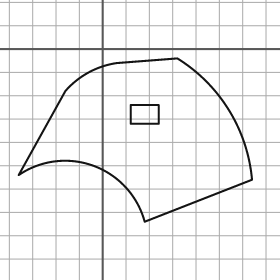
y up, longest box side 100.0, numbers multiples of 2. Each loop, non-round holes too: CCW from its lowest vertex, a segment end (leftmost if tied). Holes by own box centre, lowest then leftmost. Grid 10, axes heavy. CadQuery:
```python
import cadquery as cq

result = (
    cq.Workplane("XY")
    .moveTo(18.0, -74.0)
    .lineTo(64.0, -56.0)
    .threePointArc((54.0, -26.0), (32.0, -4.0))
    .lineTo(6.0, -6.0)
    .threePointArc((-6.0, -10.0), (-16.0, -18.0))
    .lineTo(-36.0, -54.0)
    .threePointArc((-4.0, -50.0), (18.0, -74.0))
    .close()
    .moveTo(12.0, -32.0)
    .lineTo(24.0, -32.0)
    .lineTo(24.0, -24.0)
    .lineTo(12.0, -24.0)
    .close()
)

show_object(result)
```